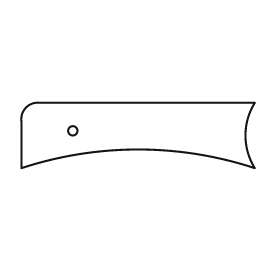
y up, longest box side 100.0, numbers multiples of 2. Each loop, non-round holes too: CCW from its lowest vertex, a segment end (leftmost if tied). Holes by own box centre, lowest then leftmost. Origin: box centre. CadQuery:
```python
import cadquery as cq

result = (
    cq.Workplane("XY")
    .moveTo(-50.0, -14.0)
    .threePointArc((0.0, -6.0), (50.0, -14.0))
    .threePointArc((46.0, 0.0), (50.0, 14.0))
    .lineTo(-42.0, 14.0)
    .threePointArc((-48.0, 12.0), (-50.0, 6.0))
    .close()
    .moveTo(-28.0, 2.0)
    .circle(2.0)
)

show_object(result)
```